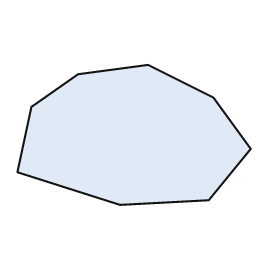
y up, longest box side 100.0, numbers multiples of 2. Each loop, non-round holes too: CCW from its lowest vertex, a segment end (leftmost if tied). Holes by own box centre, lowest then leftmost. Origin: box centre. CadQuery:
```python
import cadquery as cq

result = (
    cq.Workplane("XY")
    .moveTo(-6.0, -30.0)
    .lineTo(32.0, -28.0)
    .lineTo(50.0, -6.0)
    .lineTo(34.0, 16.0)
    .lineTo(6.0, 30.0)
    .lineTo(-24.0, 26.0)
    .lineTo(-44.0, 12.0)
    .lineTo(-50.0, -16.0)
    .close()
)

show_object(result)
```